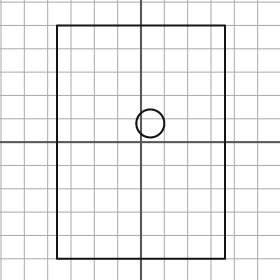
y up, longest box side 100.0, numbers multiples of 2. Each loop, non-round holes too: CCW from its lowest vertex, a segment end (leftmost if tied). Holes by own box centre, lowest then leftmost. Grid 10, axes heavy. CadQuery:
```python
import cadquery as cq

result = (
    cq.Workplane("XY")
    .moveTo(-36.0, -50.0)
    .lineTo(36.0, -50.0)
    .lineTo(36.0, 50.0)
    .lineTo(-36.0, 50.0)
    .close()
    .moveTo(4.0, 8.0)
    .circle(6.0)
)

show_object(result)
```